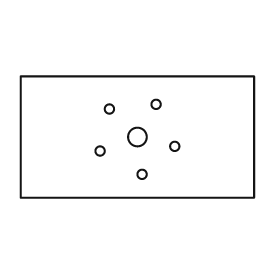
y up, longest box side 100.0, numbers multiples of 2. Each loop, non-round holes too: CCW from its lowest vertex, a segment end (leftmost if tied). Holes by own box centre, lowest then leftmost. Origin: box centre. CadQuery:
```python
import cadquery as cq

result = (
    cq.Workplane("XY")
    .moveTo(-50.0, -26.0)
    .lineTo(50.0, -26.0)
    .lineTo(50.0, 26.0)
    .lineTo(-50.0, 26.0)
    .close()
    .moveTo(2.0, -16.0)
    .circle(2.0)
    .moveTo(-16.0, -6.0)
    .circle(2.0)
    .moveTo(16.0, -4.0)
    .circle(2.0)
    .moveTo(0.0, 0.0)
    .circle(4.0)
    .moveTo(-12.0, 12.0)
    .circle(2.0)
    .moveTo(8.0, 14.0)
    .circle(2.0)
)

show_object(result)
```